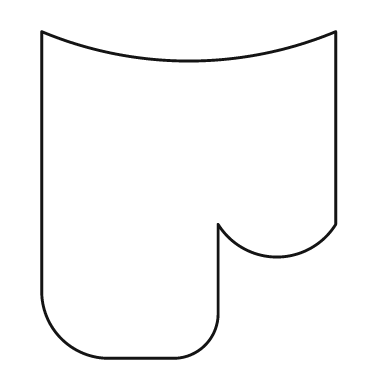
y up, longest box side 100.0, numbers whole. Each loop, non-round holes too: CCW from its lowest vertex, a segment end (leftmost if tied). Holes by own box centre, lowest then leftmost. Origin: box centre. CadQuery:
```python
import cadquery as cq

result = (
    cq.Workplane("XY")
    .moveTo(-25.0, -50.0)
    .lineTo(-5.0, -50.0)
    .threePointArc((5.0, -46.0), (9.0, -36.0))
    .lineTo(9.0, -9.0)
    .threePointArc((27.0, -19.0), (45.0, -9.0))
    .lineTo(45.0, 50.0)
    .threePointArc((0.0, 41.0), (-45.0, 50.0))
    .lineTo(-45.0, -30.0)
    .threePointArc((-39.0, -44.0), (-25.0, -50.0))
    .close()
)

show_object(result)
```